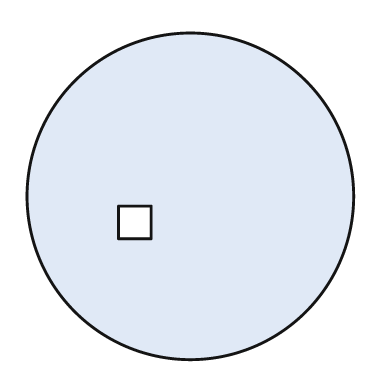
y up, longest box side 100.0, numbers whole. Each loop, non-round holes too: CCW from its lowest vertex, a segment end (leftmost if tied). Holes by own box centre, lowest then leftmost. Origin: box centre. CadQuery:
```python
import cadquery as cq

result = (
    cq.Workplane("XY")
    .moveTo(0.0, 0.0)
    .circle(50.0)
    .moveTo(-22.0, -13.0)
    .lineTo(-12.0, -13.0)
    .lineTo(-12.0, -3.0)
    .lineTo(-22.0, -3.0)
    .close()
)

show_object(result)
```